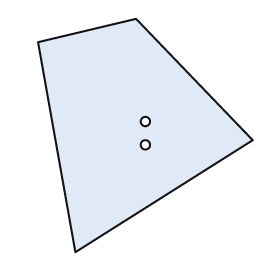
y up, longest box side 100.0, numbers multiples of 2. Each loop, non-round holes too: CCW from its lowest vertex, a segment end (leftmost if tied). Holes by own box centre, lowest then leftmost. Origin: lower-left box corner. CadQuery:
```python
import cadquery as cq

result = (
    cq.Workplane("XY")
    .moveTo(16.0, 0.0)
    .lineTo(92.0, 48.0)
    .lineTo(42.0, 100.0)
    .lineTo(0.0, 90.0)
    .close()
    .moveTo(46.0, 46.0)
    .circle(2.0)
    .moveTo(46.0, 56.0)
    .circle(2.0)
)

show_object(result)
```